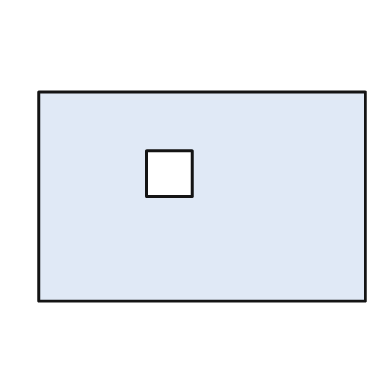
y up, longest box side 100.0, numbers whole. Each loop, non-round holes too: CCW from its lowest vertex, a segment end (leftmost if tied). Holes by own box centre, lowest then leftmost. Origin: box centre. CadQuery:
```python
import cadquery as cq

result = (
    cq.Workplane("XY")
    .moveTo(-50.0, -32.0)
    .lineTo(50.0, -32.0)
    .lineTo(50.0, 32.0)
    .lineTo(-50.0, 32.0)
    .close()
    .moveTo(-17.0, 0.0)
    .lineTo(-3.0, 0.0)
    .lineTo(-3.0, 14.0)
    .lineTo(-17.0, 14.0)
    .close()
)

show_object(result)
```